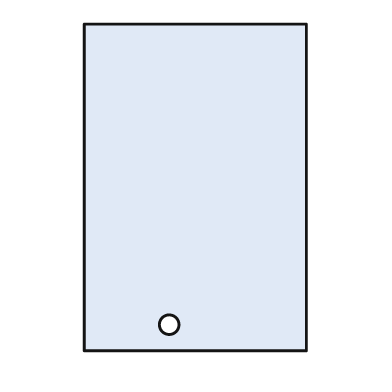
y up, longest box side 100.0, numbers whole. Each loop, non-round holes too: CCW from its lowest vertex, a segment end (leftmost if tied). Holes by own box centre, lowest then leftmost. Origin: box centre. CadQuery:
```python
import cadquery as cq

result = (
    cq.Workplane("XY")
    .moveTo(-34.0, -50.0)
    .lineTo(34.0, -50.0)
    .lineTo(34.0, 50.0)
    .lineTo(-34.0, 50.0)
    .close()
    .moveTo(-8.0, -42.0)
    .circle(3.0)
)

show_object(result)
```